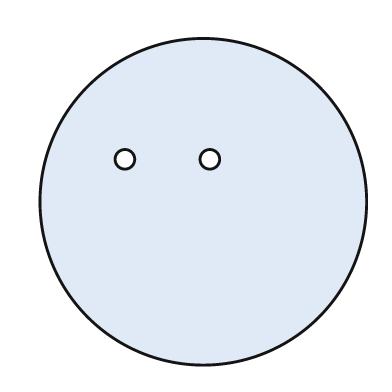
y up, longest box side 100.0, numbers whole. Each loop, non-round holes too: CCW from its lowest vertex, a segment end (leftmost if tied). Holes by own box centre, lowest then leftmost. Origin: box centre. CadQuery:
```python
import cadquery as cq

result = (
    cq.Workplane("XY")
    .moveTo(0.0, 0.0)
    .circle(50.0)
    .moveTo(-24.0, 13.0)
    .circle(3.0)
    .moveTo(2.0, 13.0)
    .circle(3.0)
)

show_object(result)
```